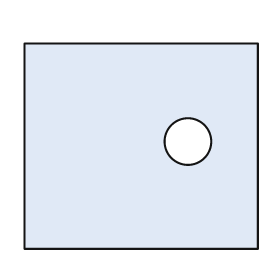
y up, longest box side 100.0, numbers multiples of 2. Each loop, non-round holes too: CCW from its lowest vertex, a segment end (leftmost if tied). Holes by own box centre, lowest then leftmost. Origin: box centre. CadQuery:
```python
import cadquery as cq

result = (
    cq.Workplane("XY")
    .moveTo(-50.0, -44.0)
    .lineTo(50.0, -44.0)
    .lineTo(50.0, 44.0)
    .lineTo(-50.0, 44.0)
    .close()
    .moveTo(20.0, 2.0)
    .circle(10.0)
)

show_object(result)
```